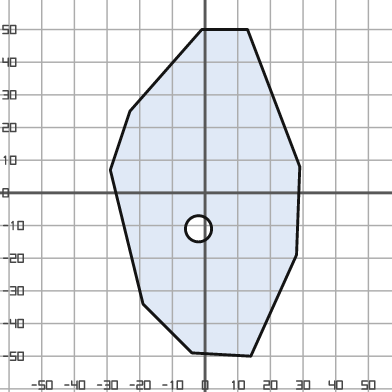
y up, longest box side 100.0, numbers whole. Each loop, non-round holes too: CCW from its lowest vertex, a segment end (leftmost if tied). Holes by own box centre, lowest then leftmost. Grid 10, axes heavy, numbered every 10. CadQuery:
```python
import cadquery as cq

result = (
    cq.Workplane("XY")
    .moveTo(14.0, -50.0)
    .lineTo(28.0, -19.0)
    .lineTo(29.0, 8.0)
    .lineTo(13.0, 50.0)
    .lineTo(-1.0, 50.0)
    .lineTo(-23.0, 25.0)
    .lineTo(-29.0, 7.0)
    .lineTo(-19.0, -34.0)
    .lineTo(-4.0, -49.0)
    .close()
    .moveTo(-2.0, -11.0)
    .circle(4.0)
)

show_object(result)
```